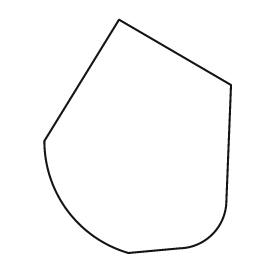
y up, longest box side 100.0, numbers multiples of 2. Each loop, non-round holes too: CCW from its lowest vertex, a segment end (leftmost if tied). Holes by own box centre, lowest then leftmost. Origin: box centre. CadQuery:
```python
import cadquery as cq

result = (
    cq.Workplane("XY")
    .moveTo(-4.0, -50.0)
    .lineTo(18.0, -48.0)
    .threePointArc((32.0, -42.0), (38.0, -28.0))
    .lineTo(40.0, 22.0)
    .lineTo(-8.0, 50.0)
    .lineTo(-40.0, -2.0)
    .threePointArc((-30.0, -32.0), (-4.0, -50.0))
    .close()
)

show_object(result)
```